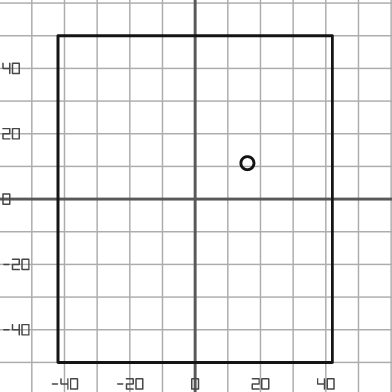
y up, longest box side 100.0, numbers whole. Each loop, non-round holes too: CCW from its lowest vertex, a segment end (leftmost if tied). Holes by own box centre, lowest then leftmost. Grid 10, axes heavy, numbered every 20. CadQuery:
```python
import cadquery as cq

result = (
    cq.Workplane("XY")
    .moveTo(-42.0, -50.0)
    .lineTo(42.0, -50.0)
    .lineTo(42.0, 50.0)
    .lineTo(-42.0, 50.0)
    .close()
    .moveTo(16.0, 11.0)
    .circle(2.0)
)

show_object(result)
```